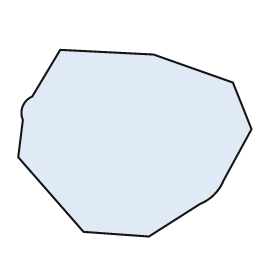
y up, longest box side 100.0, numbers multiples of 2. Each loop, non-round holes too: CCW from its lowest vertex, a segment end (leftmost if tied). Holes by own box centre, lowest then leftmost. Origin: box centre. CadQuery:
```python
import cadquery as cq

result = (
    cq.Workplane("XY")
    .moveTo(6.0, -40.0)
    .lineTo(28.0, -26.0)
    .threePointArc((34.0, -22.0), (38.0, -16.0))
    .lineTo(50.0, 6.0)
    .lineTo(42.0, 26.0)
    .lineTo(8.0, 38.0)
    .lineTo(-32.0, 40.0)
    .lineTo(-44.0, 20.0)
    .threePointArc((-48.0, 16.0), (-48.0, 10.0))
    .lineTo(-50.0, -6.0)
    .lineTo(-22.0, -38.0)
    .close()
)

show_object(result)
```